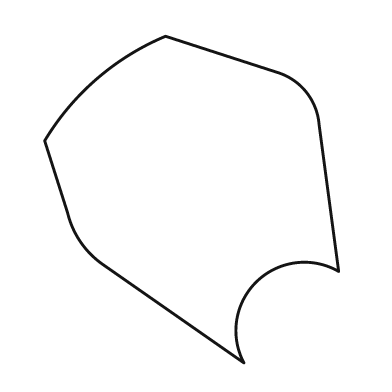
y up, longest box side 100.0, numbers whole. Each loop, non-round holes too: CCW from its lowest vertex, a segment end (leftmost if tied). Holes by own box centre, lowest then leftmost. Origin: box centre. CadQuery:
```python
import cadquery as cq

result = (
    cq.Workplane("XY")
    .moveTo(16.0, -50.0)
    .threePointArc((20.0, -25.0), (45.0, -22.0))
    .lineTo(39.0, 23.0)
    .threePointArc((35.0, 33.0), (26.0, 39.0))
    .lineTo(-8.0, 50.0)
    .threePointArc((-29.0, 37.0), (-45.0, 18.0))
    .lineTo(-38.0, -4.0)
    .threePointArc((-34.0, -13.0), (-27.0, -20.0))
    .close()
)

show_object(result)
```